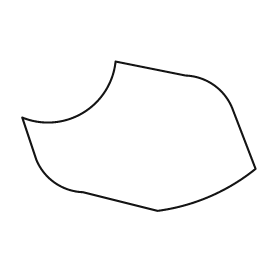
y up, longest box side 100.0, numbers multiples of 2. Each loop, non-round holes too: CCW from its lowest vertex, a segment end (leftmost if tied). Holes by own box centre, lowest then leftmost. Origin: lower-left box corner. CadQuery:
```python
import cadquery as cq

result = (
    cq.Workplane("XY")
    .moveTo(58.0, 0.0)
    .threePointArc((80.0, 6.0), (100.0, 18.0))
    .lineTo(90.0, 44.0)
    .threePointArc((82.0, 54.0), (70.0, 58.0))
    .lineTo(40.0, 64.0)
    .threePointArc((26.0, 42.0), (0.0, 40.0))
    .lineTo(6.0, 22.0)
    .threePointArc((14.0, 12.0), (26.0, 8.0))
    .close()
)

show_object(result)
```